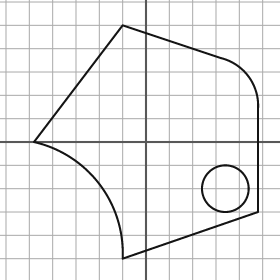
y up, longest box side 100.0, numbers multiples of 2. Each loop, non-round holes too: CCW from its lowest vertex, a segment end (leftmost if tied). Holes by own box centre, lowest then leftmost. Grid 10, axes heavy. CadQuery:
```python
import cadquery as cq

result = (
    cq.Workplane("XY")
    .moveTo(-10.0, -50.0)
    .lineTo(48.0, -30.0)
    .lineTo(48.0, 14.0)
    .threePointArc((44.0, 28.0), (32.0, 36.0))
    .lineTo(-10.0, 50.0)
    .lineTo(-48.0, 0.0)
    .threePointArc((-20.0, -18.0), (-10.0, -50.0))
    .close()
    .moveTo(34.0, -20.0)
    .circle(10.0)
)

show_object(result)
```